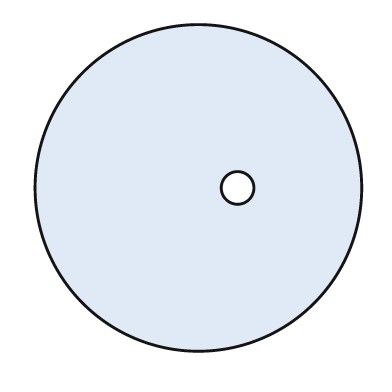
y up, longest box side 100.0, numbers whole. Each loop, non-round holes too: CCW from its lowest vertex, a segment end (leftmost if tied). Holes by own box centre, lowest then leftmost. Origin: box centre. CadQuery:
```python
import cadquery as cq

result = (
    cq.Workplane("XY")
    .moveTo(0.0, 0.0)
    .circle(50.0)
    .moveTo(12.0, 0.0)
    .circle(5.0)
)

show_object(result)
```